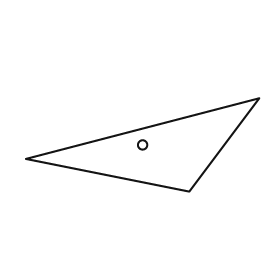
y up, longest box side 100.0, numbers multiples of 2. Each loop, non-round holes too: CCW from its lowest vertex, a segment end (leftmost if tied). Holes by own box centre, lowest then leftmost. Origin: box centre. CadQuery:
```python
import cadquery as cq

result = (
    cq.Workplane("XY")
    .moveTo(20.0, -20.0)
    .lineTo(50.0, 20.0)
    .lineTo(-50.0, -6.0)
    .close()
    .moveTo(0.0, 0.0)
    .circle(2.0)
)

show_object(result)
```